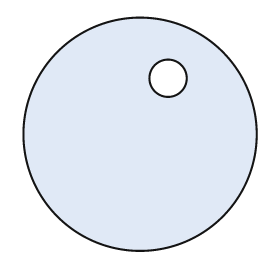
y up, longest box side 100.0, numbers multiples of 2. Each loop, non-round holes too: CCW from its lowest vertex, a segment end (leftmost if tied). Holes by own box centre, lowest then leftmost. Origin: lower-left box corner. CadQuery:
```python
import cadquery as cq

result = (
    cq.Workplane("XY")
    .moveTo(50.0, 50.0)
    .circle(50.0)
    .moveTo(62.0, 74.0)
    .circle(8.0)
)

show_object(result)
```